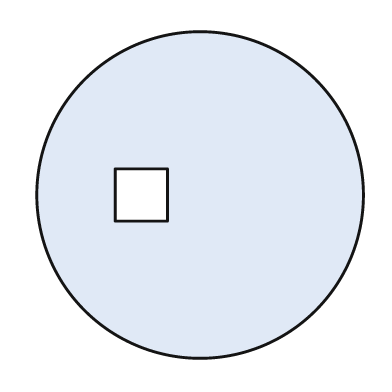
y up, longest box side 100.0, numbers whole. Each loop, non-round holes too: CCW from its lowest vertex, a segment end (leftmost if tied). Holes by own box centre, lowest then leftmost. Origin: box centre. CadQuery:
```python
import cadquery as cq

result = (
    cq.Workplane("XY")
    .moveTo(0.0, 0.0)
    .circle(50.0)
    .moveTo(-26.0, -8.0)
    .lineTo(-10.0, -8.0)
    .lineTo(-10.0, 8.0)
    .lineTo(-26.0, 8.0)
    .close()
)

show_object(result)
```